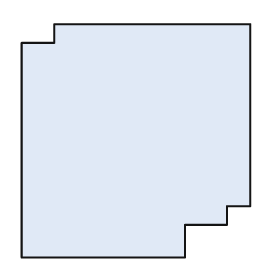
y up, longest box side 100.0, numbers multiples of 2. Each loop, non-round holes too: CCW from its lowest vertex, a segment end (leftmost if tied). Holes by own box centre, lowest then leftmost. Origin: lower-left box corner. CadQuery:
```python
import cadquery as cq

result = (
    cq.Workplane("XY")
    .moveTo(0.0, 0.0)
    .lineTo(70.0, 0.0)
    .lineTo(70.0, 14.0)
    .lineTo(88.0, 14.0)
    .lineTo(88.0, 22.0)
    .lineTo(98.0, 22.0)
    .lineTo(98.0, 100.0)
    .lineTo(14.0, 100.0)
    .lineTo(14.0, 92.0)
    .lineTo(0.0, 92.0)
    .close()
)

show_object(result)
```